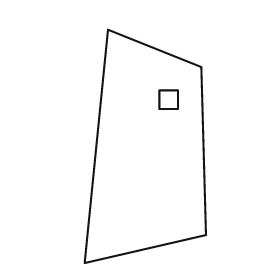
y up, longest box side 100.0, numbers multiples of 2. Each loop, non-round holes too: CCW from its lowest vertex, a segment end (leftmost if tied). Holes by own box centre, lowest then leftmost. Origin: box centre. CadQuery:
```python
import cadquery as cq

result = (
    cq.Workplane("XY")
    .moveTo(-26.0, -50.0)
    .lineTo(26.0, -38.0)
    .lineTo(24.0, 34.0)
    .lineTo(-16.0, 50.0)
    .close()
    .moveTo(6.0, 16.0)
    .lineTo(14.0, 16.0)
    .lineTo(14.0, 24.0)
    .lineTo(6.0, 24.0)
    .close()
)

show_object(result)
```